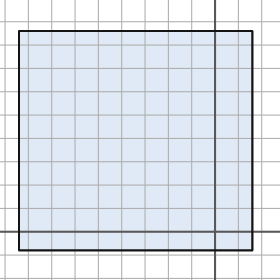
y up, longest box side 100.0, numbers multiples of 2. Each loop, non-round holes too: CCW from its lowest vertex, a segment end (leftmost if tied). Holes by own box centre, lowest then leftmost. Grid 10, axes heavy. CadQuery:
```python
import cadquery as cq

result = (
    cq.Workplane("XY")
    .moveTo(-84.0, -8.0)
    .lineTo(16.0, -8.0)
    .lineTo(16.0, 86.0)
    .lineTo(-84.0, 86.0)
    .close()
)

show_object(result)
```